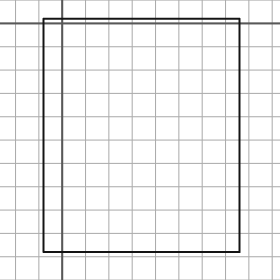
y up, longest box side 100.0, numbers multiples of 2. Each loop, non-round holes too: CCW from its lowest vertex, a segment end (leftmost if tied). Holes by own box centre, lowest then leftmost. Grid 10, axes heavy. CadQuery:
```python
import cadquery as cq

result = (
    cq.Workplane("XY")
    .moveTo(-8.0, -98.0)
    .lineTo(76.0, -98.0)
    .lineTo(76.0, 2.0)
    .lineTo(-8.0, 2.0)
    .close()
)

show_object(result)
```